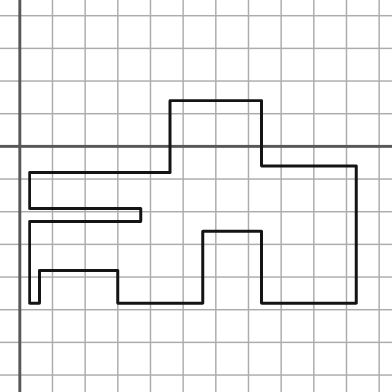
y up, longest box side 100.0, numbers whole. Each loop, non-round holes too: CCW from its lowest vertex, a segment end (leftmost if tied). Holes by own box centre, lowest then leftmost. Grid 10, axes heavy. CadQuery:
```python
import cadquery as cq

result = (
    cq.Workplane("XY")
    .moveTo(3.0, -48.0)
    .lineTo(6.0, -48.0)
    .lineTo(6.0, -38.0)
    .lineTo(30.0, -38.0)
    .lineTo(30.0, -48.0)
    .lineTo(56.0, -48.0)
    .lineTo(56.0, -26.0)
    .lineTo(74.0, -26.0)
    .lineTo(74.0, -48.0)
    .lineTo(103.0, -48.0)
    .lineTo(103.0, -6.0)
    .lineTo(74.0, -6.0)
    .lineTo(74.0, 14.0)
    .lineTo(46.0, 14.0)
    .lineTo(46.0, -8.0)
    .lineTo(3.0, -8.0)
    .lineTo(3.0, -19.0)
    .lineTo(37.0, -19.0)
    .lineTo(37.0, -23.0)
    .lineTo(3.0, -23.0)
    .close()
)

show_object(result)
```